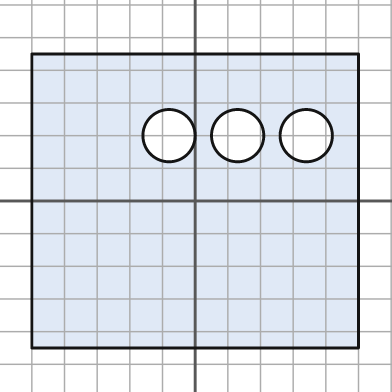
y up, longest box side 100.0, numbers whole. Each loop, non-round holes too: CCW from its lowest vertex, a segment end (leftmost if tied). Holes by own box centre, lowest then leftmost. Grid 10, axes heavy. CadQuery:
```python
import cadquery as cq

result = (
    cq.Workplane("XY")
    .moveTo(-50.0, -45.0)
    .lineTo(50.0, -45.0)
    .lineTo(50.0, 45.0)
    .lineTo(-50.0, 45.0)
    .close()
    .moveTo(-8.0, 20.0)
    .circle(8.0)
    .moveTo(13.0, 20.0)
    .circle(8.0)
    .moveTo(34.0, 20.0)
    .circle(8.0)
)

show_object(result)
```